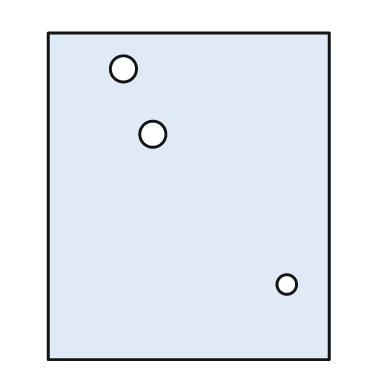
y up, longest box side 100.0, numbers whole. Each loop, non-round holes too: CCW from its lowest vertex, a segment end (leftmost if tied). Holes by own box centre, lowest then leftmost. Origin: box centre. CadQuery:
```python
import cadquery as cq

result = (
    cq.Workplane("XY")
    .moveTo(-43.0, -50.0)
    .lineTo(43.0, -50.0)
    .lineTo(43.0, 50.0)
    .lineTo(-43.0, 50.0)
    .close()
    .moveTo(30.0, -27.0)
    .circle(3.0)
    .moveTo(-11.0, 19.0)
    .circle(4.0)
    .moveTo(-20.0, 39.0)
    .circle(4.0)
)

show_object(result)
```